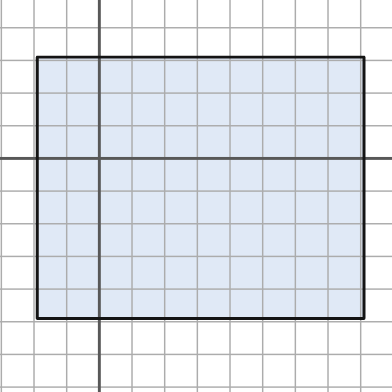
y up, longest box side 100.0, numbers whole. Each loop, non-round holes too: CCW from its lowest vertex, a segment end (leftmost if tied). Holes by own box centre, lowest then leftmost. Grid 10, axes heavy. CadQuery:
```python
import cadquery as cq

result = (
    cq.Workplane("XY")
    .moveTo(-19.0, -49.0)
    .lineTo(81.0, -49.0)
    .lineTo(81.0, 31.0)
    .lineTo(-19.0, 31.0)
    .close()
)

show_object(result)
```